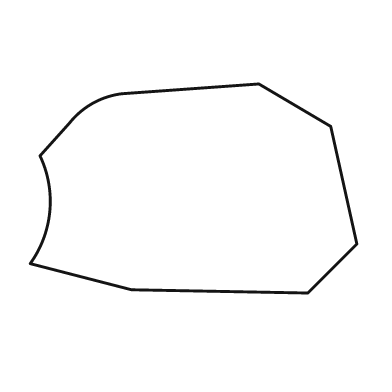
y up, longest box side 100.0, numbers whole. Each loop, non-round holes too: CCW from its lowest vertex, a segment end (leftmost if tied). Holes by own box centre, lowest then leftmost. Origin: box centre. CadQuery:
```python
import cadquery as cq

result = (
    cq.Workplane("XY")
    .moveTo(35.0, -32.0)
    .lineTo(50.0, -17.0)
    .lineTo(42.0, 19.0)
    .lineTo(20.0, 32.0)
    .lineTo(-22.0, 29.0)
    .threePointArc((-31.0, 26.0), (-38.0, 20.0))
    .lineTo(-47.0, 10.0)
    .threePointArc((-44.0, -7.0), (-50.0, -23.0))
    .lineTo(-19.0, -31.0)
    .close()
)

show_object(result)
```